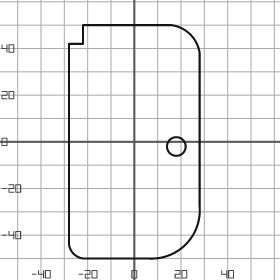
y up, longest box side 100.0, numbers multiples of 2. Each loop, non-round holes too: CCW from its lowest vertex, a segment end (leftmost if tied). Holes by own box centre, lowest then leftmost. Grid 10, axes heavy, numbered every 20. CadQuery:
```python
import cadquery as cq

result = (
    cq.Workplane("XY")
    .moveTo(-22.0, -50.0)
    .lineTo(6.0, -50.0)
    .threePointArc((22.0, -44.0), (28.0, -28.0))
    .lineTo(28.0, 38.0)
    .threePointArc((24.0, 46.0), (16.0, 50.0))
    .lineTo(-22.0, 50.0)
    .lineTo(-22.0, 42.0)
    .lineTo(-28.0, 42.0)
    .lineTo(-28.0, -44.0)
    .threePointArc((-26.0, -48.0), (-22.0, -50.0))
    .close()
    .moveTo(18.0, -2.0)
    .circle(4.0)
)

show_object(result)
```